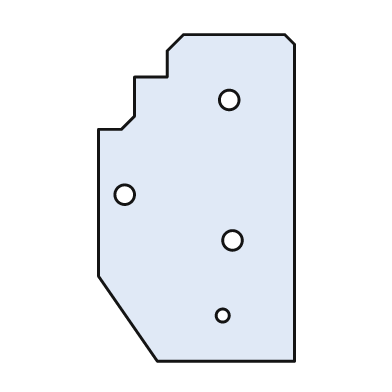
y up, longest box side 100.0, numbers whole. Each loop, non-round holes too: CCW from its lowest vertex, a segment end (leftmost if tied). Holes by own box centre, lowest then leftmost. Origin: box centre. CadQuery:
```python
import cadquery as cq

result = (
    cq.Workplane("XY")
    .moveTo(-12.0, -50.0)
    .lineTo(30.0, -50.0)
    .lineTo(30.0, 47.0)
    .lineTo(27.0, 50.0)
    .lineTo(-4.0, 50.0)
    .lineTo(-9.0, 45.0)
    .lineTo(-9.0, 37.0)
    .lineTo(-19.0, 37.0)
    .lineTo(-19.0, 25.0)
    .lineTo(-23.0, 21.0)
    .lineTo(-30.0, 21.0)
    .lineTo(-30.0, -24.0)
    .close()
    .moveTo(8.0, -36.0)
    .circle(2.0)
    .moveTo(11.0, -13.0)
    .circle(3.0)
    .moveTo(-22.0, 1.0)
    .circle(3.0)
    .moveTo(10.0, 30.0)
    .circle(3.0)
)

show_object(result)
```